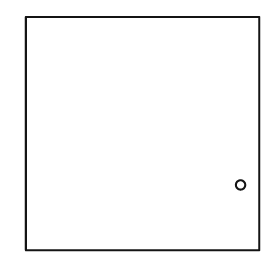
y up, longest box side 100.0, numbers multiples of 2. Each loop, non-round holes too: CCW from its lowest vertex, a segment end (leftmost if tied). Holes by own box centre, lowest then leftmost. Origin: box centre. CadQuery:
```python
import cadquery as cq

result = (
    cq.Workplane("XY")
    .moveTo(-50.0, -50.0)
    .lineTo(50.0, -50.0)
    .lineTo(50.0, 50.0)
    .lineTo(-50.0, 50.0)
    .close()
    .moveTo(42.0, -22.0)
    .circle(2.0)
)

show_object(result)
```